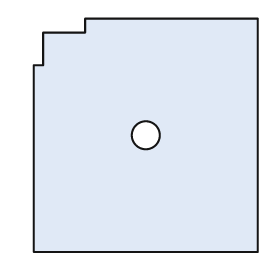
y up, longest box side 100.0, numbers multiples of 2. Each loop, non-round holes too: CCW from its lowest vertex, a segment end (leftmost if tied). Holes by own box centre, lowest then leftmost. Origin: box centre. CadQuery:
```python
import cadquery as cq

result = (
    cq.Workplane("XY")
    .moveTo(-48.0, -50.0)
    .lineTo(48.0, -50.0)
    .lineTo(48.0, 50.0)
    .lineTo(-26.0, 50.0)
    .lineTo(-26.0, 44.0)
    .lineTo(-44.0, 44.0)
    .lineTo(-44.0, 30.0)
    .lineTo(-48.0, 30.0)
    .close()
    .moveTo(0.0, 0.0)
    .circle(6.0)
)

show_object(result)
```